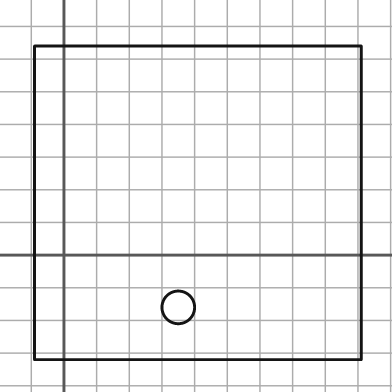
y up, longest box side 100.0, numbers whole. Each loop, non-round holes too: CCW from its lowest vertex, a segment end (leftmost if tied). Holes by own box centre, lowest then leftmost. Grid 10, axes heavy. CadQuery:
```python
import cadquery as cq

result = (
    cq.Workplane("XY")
    .moveTo(-9.0, -32.0)
    .lineTo(91.0, -32.0)
    .lineTo(91.0, 64.0)
    .lineTo(-9.0, 64.0)
    .close()
    .moveTo(35.0, -16.0)
    .circle(5.0)
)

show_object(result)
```